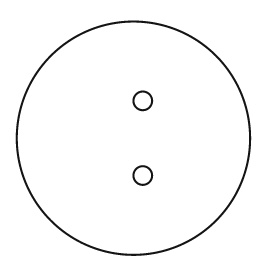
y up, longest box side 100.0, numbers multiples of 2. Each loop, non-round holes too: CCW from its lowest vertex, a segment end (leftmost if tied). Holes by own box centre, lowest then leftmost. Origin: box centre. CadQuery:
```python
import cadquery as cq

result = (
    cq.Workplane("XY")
    .moveTo(0.0, 0.0)
    .circle(50.0)
    .moveTo(4.0, -16.0)
    .circle(4.0)
    .moveTo(4.0, 16.0)
    .circle(4.0)
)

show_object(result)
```